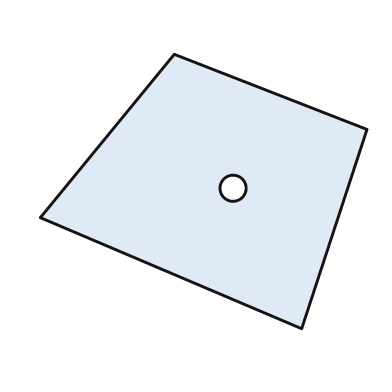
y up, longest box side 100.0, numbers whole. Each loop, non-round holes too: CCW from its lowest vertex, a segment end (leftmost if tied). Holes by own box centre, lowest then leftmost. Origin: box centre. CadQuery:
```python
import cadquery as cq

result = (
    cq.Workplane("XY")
    .moveTo(30.0, -42.0)
    .lineTo(50.0, 19.0)
    .lineTo(-9.0, 42.0)
    .lineTo(-50.0, -8.0)
    .close()
    .moveTo(9.0, 1.0)
    .circle(4.0)
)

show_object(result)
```